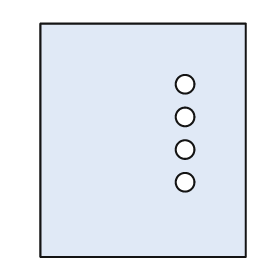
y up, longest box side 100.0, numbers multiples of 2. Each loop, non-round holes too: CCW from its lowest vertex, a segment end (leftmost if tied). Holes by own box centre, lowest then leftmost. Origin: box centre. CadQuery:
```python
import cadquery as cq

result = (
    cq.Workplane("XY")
    .moveTo(-44.0, -50.0)
    .lineTo(44.0, -50.0)
    .lineTo(44.0, 50.0)
    .lineTo(-44.0, 50.0)
    .close()
    .moveTo(18.0, -18.0)
    .circle(4.0)
    .moveTo(18.0, -4.0)
    .circle(4.0)
    .moveTo(18.0, 10.0)
    .circle(4.0)
    .moveTo(18.0, 24.0)
    .circle(4.0)
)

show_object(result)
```